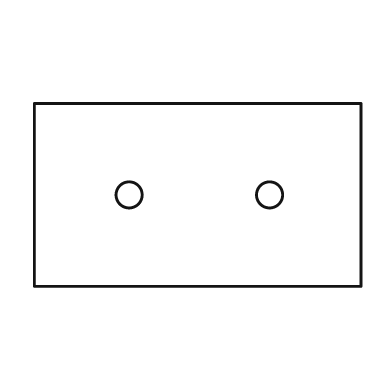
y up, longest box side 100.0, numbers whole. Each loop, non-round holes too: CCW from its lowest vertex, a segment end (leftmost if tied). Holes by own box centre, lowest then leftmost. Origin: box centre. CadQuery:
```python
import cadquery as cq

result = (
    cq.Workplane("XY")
    .moveTo(-50.0, -28.0)
    .lineTo(50.0, -28.0)
    .lineTo(50.0, 28.0)
    .lineTo(-50.0, 28.0)
    .close()
    .moveTo(-21.0, 0.0)
    .circle(4.0)
    .moveTo(22.0, 0.0)
    .circle(4.0)
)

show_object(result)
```